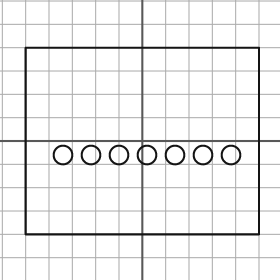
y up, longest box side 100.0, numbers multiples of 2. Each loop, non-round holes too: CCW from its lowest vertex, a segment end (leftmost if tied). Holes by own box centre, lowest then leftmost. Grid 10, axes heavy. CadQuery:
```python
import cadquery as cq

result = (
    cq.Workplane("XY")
    .moveTo(-50.0, -40.0)
    .lineTo(50.0, -40.0)
    .lineTo(50.0, 40.0)
    .lineTo(-50.0, 40.0)
    .close()
    .moveTo(-34.0, -6.0)
    .circle(4.0)
    .moveTo(-22.0, -6.0)
    .circle(4.0)
    .moveTo(-10.0, -6.0)
    .circle(4.0)
    .moveTo(2.0, -6.0)
    .circle(4.0)
    .moveTo(14.0, -6.0)
    .circle(4.0)
    .moveTo(26.0, -6.0)
    .circle(4.0)
    .moveTo(38.0, -6.0)
    .circle(4.0)
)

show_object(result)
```